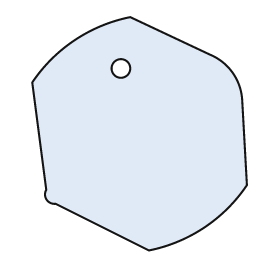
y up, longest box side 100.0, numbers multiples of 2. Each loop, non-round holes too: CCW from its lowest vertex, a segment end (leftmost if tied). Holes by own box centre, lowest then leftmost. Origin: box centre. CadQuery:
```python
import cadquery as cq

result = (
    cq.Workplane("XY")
    .moveTo(4.0, -50.0)
    .threePointArc((28.0, -40.0), (46.0, -22.0))
    .lineTo(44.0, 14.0)
    .threePointArc((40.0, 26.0), (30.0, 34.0))
    .lineTo(-4.0, 50.0)
    .threePointArc((-28.0, 40.0), (-46.0, 22.0))
    .lineTo(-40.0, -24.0)
    .threePointArc((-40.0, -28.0), (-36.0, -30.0))
    .close()
    .moveTo(-8.0, 28.0)
    .circle(4.0)
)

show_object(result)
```